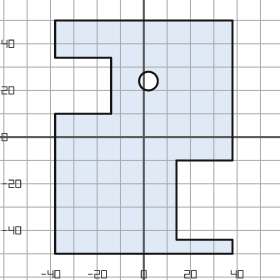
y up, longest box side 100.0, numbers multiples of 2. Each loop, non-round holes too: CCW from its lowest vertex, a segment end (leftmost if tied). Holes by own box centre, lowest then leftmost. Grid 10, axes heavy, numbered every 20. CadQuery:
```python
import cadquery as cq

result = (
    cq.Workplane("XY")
    .moveTo(-38.0, -50.0)
    .lineTo(38.0, -50.0)
    .lineTo(38.0, -44.0)
    .lineTo(14.0, -44.0)
    .lineTo(14.0, -10.0)
    .lineTo(38.0, -10.0)
    .lineTo(38.0, 50.0)
    .lineTo(-38.0, 50.0)
    .lineTo(-38.0, 34.0)
    .lineTo(-14.0, 34.0)
    .lineTo(-14.0, 10.0)
    .lineTo(-38.0, 10.0)
    .close()
    .moveTo(2.0, 24.0)
    .circle(4.0)
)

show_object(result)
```